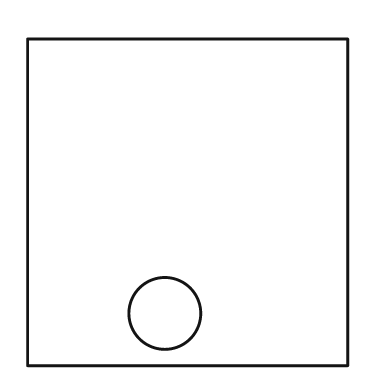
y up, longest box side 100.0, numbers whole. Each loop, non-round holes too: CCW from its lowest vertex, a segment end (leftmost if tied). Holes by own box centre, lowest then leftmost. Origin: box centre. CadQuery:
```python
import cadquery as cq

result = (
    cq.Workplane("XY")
    .moveTo(-49.0, -50.0)
    .lineTo(49.0, -50.0)
    .lineTo(49.0, 50.0)
    .lineTo(-49.0, 50.0)
    .close()
    .moveTo(-7.0, -34.0)
    .circle(11.0)
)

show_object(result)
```